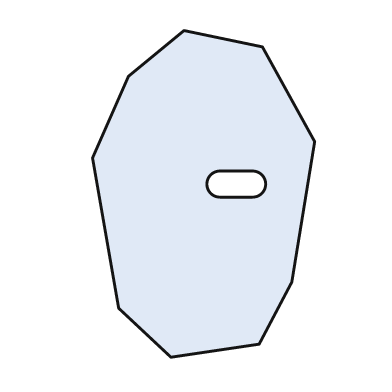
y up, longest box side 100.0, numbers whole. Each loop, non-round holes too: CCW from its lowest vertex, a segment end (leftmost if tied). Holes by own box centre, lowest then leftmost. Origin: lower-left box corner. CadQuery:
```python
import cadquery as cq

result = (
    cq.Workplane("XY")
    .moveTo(24.0, 0.0)
    .lineTo(51.0, 4.0)
    .lineTo(61.0, 23.0)
    .lineTo(68.0, 66.0)
    .lineTo(52.0, 95.0)
    .lineTo(28.0, 100.0)
    .lineTo(11.0, 86.0)
    .lineTo(0.0, 61.0)
    .lineTo(8.0, 15.0)
    .close()
    .moveTo(39.0, 49.0)
    .lineTo(49.0, 49.0)
    .threePointArc((53.0, 53.0), (49.0, 57.0))
    .lineTo(39.0, 57.0)
    .threePointArc((35.0, 53.0), (39.0, 49.0))
    .close()
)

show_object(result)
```